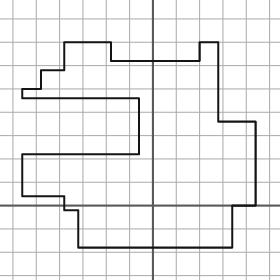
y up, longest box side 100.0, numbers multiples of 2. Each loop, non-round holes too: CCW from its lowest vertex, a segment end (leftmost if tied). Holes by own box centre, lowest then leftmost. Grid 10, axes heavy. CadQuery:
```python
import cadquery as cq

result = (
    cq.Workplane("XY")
    .moveTo(-32.0, -18.0)
    .lineTo(34.0, -18.0)
    .lineTo(34.0, 0.0)
    .lineTo(44.0, 0.0)
    .lineTo(44.0, 36.0)
    .lineTo(28.0, 36.0)
    .lineTo(28.0, 70.0)
    .lineTo(20.0, 70.0)
    .lineTo(20.0, 62.0)
    .lineTo(-18.0, 62.0)
    .lineTo(-18.0, 70.0)
    .lineTo(-38.0, 70.0)
    .lineTo(-38.0, 58.0)
    .lineTo(-48.0, 58.0)
    .lineTo(-48.0, 50.0)
    .lineTo(-56.0, 50.0)
    .lineTo(-56.0, 46.0)
    .lineTo(-6.0, 46.0)
    .lineTo(-6.0, 22.0)
    .lineTo(-56.0, 22.0)
    .lineTo(-56.0, 4.0)
    .lineTo(-38.0, 4.0)
    .lineTo(-38.0, -2.0)
    .lineTo(-32.0, -2.0)
    .close()
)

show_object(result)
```